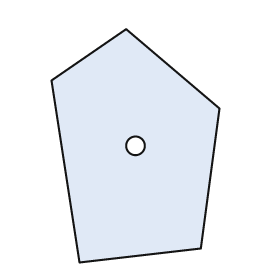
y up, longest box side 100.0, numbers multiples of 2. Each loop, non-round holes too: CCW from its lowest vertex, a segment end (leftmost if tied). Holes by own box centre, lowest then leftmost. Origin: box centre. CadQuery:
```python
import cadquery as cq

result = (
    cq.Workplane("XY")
    .moveTo(-24.0, -50.0)
    .lineTo(28.0, -44.0)
    .lineTo(36.0, 16.0)
    .lineTo(-4.0, 50.0)
    .lineTo(-36.0, 28.0)
    .close()
    .moveTo(0.0, 0.0)
    .circle(4.0)
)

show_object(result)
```